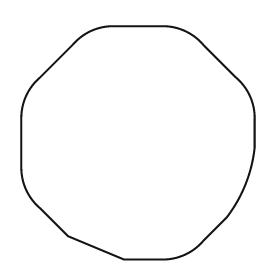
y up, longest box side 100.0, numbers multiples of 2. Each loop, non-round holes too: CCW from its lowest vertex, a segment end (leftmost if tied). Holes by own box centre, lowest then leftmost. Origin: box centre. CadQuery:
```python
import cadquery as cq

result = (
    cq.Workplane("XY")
    .moveTo(-6.0, -50.0)
    .lineTo(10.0, -50.0)
    .threePointArc((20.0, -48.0), (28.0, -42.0))
    .lineTo(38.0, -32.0)
    .threePointArc((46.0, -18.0), (50.0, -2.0))
    .lineTo(50.0, 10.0)
    .threePointArc((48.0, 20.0), (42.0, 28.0))
    .lineTo(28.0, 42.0)
    .threePointArc((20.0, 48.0), (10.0, 50.0))
    .lineTo(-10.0, 50.0)
    .threePointArc((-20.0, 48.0), (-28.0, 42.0))
    .lineTo(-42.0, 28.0)
    .threePointArc((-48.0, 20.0), (-50.0, 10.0))
    .lineTo(-50.0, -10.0)
    .threePointArc((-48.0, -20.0), (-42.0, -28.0))
    .lineTo(-30.0, -40.0)
    .close()
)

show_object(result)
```